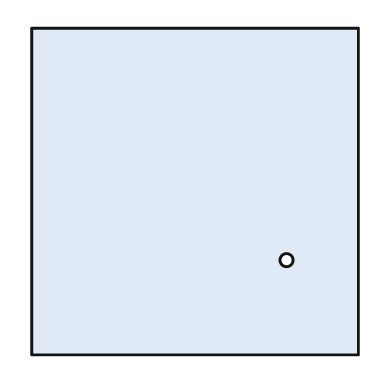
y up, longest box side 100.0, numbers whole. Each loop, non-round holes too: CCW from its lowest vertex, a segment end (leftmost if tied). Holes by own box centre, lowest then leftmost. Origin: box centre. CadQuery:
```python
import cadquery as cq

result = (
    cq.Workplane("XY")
    .moveTo(-50.0, -50.0)
    .lineTo(50.0, -50.0)
    .lineTo(50.0, 50.0)
    .lineTo(-50.0, 50.0)
    .close()
    .moveTo(28.0, -21.0)
    .circle(2.0)
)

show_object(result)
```